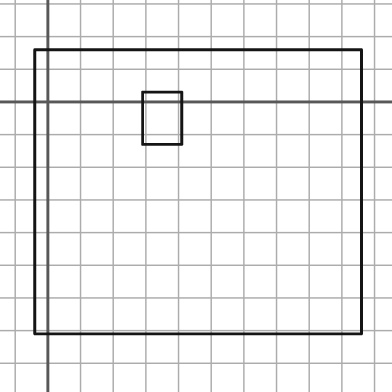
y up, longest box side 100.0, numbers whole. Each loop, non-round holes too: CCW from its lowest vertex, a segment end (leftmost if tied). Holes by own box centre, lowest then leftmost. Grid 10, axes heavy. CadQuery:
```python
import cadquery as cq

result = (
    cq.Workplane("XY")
    .moveTo(-4.0, -71.0)
    .lineTo(96.0, -71.0)
    .lineTo(96.0, 16.0)
    .lineTo(-4.0, 16.0)
    .close()
    .moveTo(29.0, -13.0)
    .lineTo(41.0, -13.0)
    .lineTo(41.0, 3.0)
    .lineTo(29.0, 3.0)
    .close()
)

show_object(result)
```